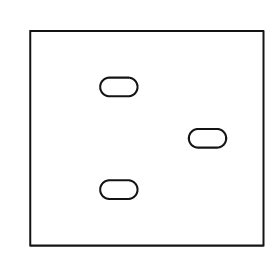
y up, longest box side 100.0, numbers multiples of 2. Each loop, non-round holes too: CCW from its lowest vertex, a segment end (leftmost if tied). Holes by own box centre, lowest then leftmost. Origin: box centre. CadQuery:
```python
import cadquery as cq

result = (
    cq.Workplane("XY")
    .moveTo(-50.0, -46.0)
    .lineTo(50.0, -46.0)
    .lineTo(50.0, 46.0)
    .lineTo(-50.0, 46.0)
    .close()
    .moveTo(-16.0, -26.0)
    .lineTo(-8.0, -26.0)
    .threePointArc((-4.0, -22.0), (-8.0, -18.0))
    .lineTo(-16.0, -18.0)
    .threePointArc((-20.0, -22.0), (-16.0, -26.0))
    .close()
    .moveTo(22.0, -4.0)
    .lineTo(30.0, -4.0)
    .threePointArc((34.0, 0.0), (30.0, 4.0))
    .lineTo(22.0, 4.0)
    .threePointArc((18.0, 0.0), (22.0, -4.0))
    .close()
    .moveTo(-16.0, 18.0)
    .lineTo(-8.0, 18.0)
    .threePointArc((-4.0, 22.0), (-8.0, 26.0))
    .lineTo(-16.0, 26.0)
    .threePointArc((-20.0, 22.0), (-16.0, 18.0))
    .close()
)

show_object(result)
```